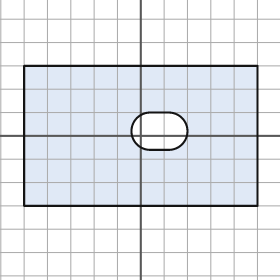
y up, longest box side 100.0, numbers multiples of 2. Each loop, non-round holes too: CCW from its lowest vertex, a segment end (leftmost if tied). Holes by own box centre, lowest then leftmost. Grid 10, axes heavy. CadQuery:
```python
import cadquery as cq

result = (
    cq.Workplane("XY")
    .moveTo(-50.0, -30.0)
    .lineTo(50.0, -30.0)
    .lineTo(50.0, 30.0)
    .lineTo(-50.0, 30.0)
    .close()
    .moveTo(4.0, -6.0)
    .lineTo(12.0, -6.0)
    .threePointArc((20.0, 2.0), (12.0, 10.0))
    .lineTo(4.0, 10.0)
    .threePointArc((-4.0, 2.0), (4.0, -6.0))
    .close()
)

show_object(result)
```